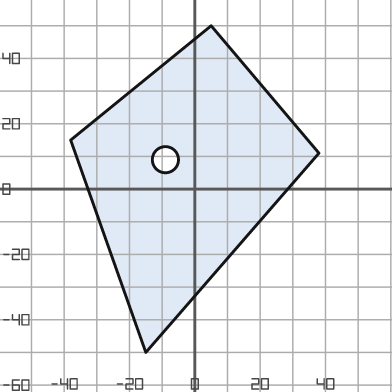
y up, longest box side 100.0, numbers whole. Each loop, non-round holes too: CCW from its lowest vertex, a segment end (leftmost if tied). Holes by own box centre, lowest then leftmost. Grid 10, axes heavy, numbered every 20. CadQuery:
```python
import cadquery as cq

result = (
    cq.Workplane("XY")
    .moveTo(-15.0, -50.0)
    .lineTo(38.0, 11.0)
    .lineTo(5.0, 50.0)
    .lineTo(-38.0, 15.0)
    .close()
    .moveTo(-9.0, 9.0)
    .circle(4.0)
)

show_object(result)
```